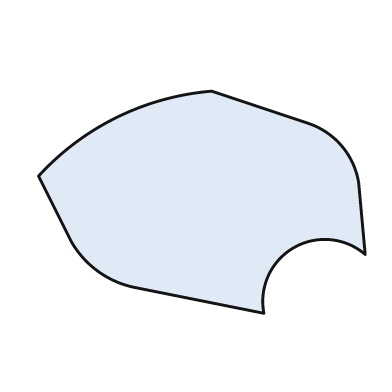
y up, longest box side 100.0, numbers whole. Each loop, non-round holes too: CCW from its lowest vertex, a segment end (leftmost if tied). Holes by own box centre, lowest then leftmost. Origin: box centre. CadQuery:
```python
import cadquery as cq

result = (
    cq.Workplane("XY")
    .moveTo(19.0, -34.0)
    .threePointArc((28.0, -14.0), (50.0, -16.0))
    .lineTo(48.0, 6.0)
    .threePointArc((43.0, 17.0), (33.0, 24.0))
    .lineTo(3.0, 34.0)
    .threePointArc((-26.0, 26.0), (-50.0, 8.0))
    .lineTo(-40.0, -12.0)
    .threePointArc((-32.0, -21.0), (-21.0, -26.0))
    .close()
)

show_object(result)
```